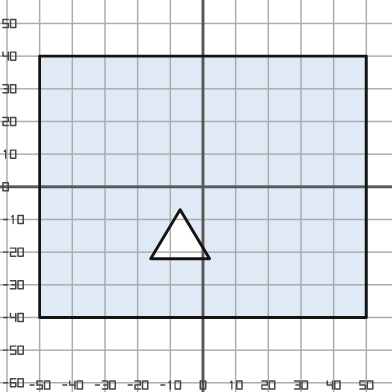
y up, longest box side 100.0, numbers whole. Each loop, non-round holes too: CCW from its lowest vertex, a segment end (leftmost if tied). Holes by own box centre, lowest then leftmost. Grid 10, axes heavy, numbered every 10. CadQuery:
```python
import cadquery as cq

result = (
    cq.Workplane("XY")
    .moveTo(-50.0, -40.0)
    .lineTo(50.0, -40.0)
    .lineTo(50.0, 40.0)
    .lineTo(-50.0, 40.0)
    .close()
    .moveTo(-16.0, -22.0)
    .lineTo(2.0, -22.0)
    .lineTo(-7.0, -7.0)
    .close()
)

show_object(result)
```